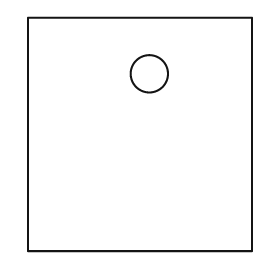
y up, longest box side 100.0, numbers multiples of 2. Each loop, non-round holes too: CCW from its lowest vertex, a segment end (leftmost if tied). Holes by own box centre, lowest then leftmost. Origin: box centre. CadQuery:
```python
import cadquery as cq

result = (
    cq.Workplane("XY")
    .moveTo(-48.0, -50.0)
    .lineTo(48.0, -50.0)
    .lineTo(48.0, 50.0)
    .lineTo(-48.0, 50.0)
    .close()
    .moveTo(4.0, 26.0)
    .circle(8.0)
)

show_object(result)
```